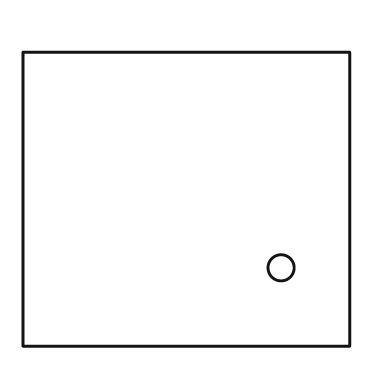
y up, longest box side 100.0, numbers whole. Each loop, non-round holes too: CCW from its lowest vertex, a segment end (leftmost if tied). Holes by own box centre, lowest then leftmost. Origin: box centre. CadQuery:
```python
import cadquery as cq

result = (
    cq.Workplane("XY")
    .moveTo(-50.0, -45.0)
    .lineTo(50.0, -45.0)
    .lineTo(50.0, 45.0)
    .lineTo(-50.0, 45.0)
    .close()
    .moveTo(29.0, -21.0)
    .circle(4.0)
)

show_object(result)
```